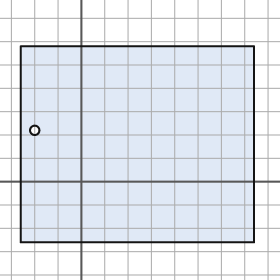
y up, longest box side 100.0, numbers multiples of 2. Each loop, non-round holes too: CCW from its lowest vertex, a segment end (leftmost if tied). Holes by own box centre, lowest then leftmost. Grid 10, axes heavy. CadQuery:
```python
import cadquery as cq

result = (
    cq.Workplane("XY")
    .moveTo(-26.0, -26.0)
    .lineTo(74.0, -26.0)
    .lineTo(74.0, 58.0)
    .lineTo(-26.0, 58.0)
    .close()
    .moveTo(-20.0, 22.0)
    .circle(2.0)
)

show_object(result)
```